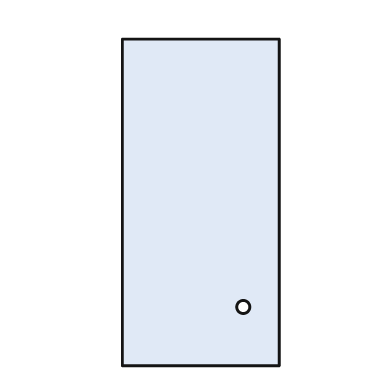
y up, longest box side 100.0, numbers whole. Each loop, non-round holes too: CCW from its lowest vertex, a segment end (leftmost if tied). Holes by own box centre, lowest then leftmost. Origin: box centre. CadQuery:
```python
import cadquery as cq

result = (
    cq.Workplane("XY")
    .moveTo(-24.0, -50.0)
    .lineTo(24.0, -50.0)
    .lineTo(24.0, 50.0)
    .lineTo(-24.0, 50.0)
    .close()
    .moveTo(13.0, -32.0)
    .circle(2.0)
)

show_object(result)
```